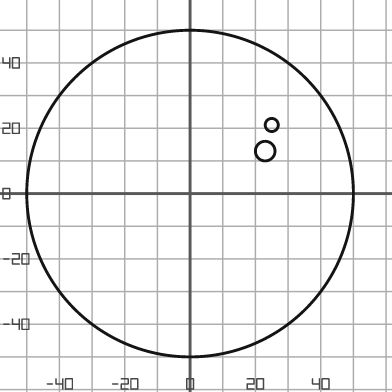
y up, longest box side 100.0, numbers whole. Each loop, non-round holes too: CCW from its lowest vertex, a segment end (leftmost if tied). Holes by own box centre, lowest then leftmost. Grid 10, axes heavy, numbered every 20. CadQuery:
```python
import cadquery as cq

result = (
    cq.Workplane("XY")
    .moveTo(0.0, 0.0)
    .circle(50.0)
    .moveTo(23.0, 13.0)
    .circle(3.0)
    .moveTo(25.0, 21.0)
    .circle(2.0)
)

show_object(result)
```